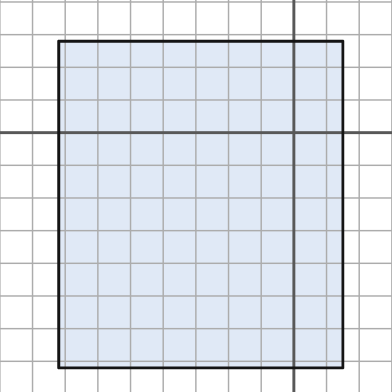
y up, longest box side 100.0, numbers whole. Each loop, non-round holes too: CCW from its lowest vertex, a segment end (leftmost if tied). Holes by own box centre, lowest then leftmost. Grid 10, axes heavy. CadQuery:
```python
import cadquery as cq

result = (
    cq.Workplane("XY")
    .moveTo(-72.0, -72.0)
    .lineTo(15.0, -72.0)
    .lineTo(15.0, 28.0)
    .lineTo(-72.0, 28.0)
    .close()
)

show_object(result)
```